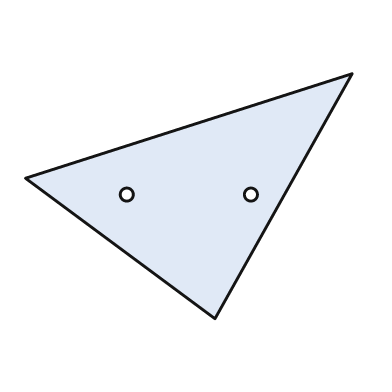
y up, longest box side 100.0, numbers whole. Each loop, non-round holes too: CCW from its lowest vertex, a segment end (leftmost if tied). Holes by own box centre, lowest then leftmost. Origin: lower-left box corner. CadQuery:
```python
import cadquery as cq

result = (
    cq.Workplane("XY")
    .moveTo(58.0, 0.0)
    .lineTo(100.0, 75.0)
    .lineTo(0.0, 43.0)
    .close()
    .moveTo(31.0, 38.0)
    .circle(2.0)
    .moveTo(69.0, 38.0)
    .circle(2.0)
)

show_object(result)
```